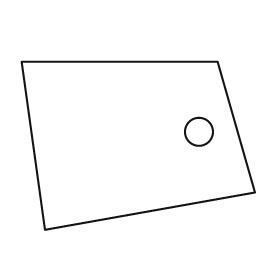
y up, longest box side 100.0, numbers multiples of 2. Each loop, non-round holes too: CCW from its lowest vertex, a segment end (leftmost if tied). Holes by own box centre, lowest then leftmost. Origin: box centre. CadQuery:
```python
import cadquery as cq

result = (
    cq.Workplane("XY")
    .moveTo(-40.0, -36.0)
    .lineTo(50.0, -20.0)
    .lineTo(34.0, 36.0)
    .lineTo(-50.0, 36.0)
    .close()
    .moveTo(26.0, 6.0)
    .circle(6.0)
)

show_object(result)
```